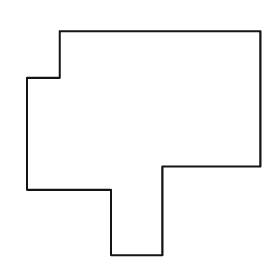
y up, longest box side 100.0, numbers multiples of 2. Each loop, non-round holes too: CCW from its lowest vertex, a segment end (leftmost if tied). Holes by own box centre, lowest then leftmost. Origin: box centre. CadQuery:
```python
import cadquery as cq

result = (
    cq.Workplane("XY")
    .moveTo(-14.0, -48.0)
    .lineTo(8.0, -48.0)
    .lineTo(8.0, -10.0)
    .lineTo(50.0, -10.0)
    .lineTo(50.0, 48.0)
    .lineTo(-36.0, 48.0)
    .lineTo(-36.0, 28.0)
    .lineTo(-50.0, 28.0)
    .lineTo(-50.0, -20.0)
    .lineTo(-14.0, -20.0)
    .close()
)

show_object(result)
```